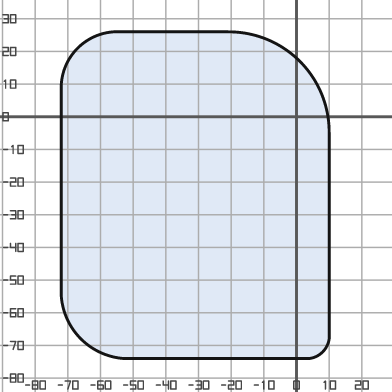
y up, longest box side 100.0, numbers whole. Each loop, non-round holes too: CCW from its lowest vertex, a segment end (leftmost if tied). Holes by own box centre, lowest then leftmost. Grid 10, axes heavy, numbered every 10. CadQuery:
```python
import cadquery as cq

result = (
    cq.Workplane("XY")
    .moveTo(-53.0, -74.0)
    .lineTo(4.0, -74.0)
    .threePointArc((8.0, -72.0), (10.0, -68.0))
    .lineTo(10.0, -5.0)
    .threePointArc((1.0, 17.0), (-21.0, 26.0))
    .lineTo(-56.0, 26.0)
    .threePointArc((-67.0, 21.0), (-72.0, 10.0))
    .lineTo(-72.0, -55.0)
    .threePointArc((-66.0, -68.0), (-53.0, -74.0))
    .close()
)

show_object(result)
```